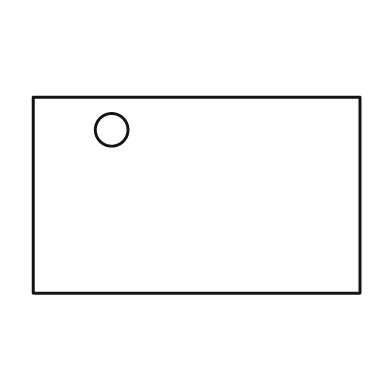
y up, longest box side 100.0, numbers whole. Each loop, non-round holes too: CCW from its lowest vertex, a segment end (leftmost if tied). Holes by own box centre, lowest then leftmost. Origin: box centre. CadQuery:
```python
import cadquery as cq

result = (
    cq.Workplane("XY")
    .moveTo(-50.0, -30.0)
    .lineTo(50.0, -30.0)
    .lineTo(50.0, 30.0)
    .lineTo(-50.0, 30.0)
    .close()
    .moveTo(-26.0, 20.0)
    .circle(5.0)
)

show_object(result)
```